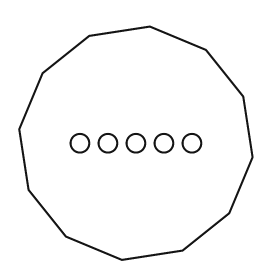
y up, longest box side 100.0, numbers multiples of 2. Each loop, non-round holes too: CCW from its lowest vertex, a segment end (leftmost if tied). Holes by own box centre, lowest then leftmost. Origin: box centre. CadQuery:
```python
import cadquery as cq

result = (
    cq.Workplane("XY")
    .moveTo(-6.0, -50.0)
    .lineTo(20.0, -46.0)
    .lineTo(40.0, -30.0)
    .lineTo(50.0, -6.0)
    .lineTo(46.0, 20.0)
    .lineTo(30.0, 40.0)
    .lineTo(6.0, 50.0)
    .lineTo(-20.0, 46.0)
    .lineTo(-40.0, 30.0)
    .lineTo(-50.0, 6.0)
    .lineTo(-46.0, -20.0)
    .lineTo(-30.0, -40.0)
    .close()
    .moveTo(-24.0, 0.0)
    .circle(4.0)
    .moveTo(-12.0, 0.0)
    .circle(4.0)
    .moveTo(0.0, 0.0)
    .circle(4.0)
    .moveTo(12.0, 0.0)
    .circle(4.0)
    .moveTo(24.0, 0.0)
    .circle(4.0)
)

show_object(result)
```